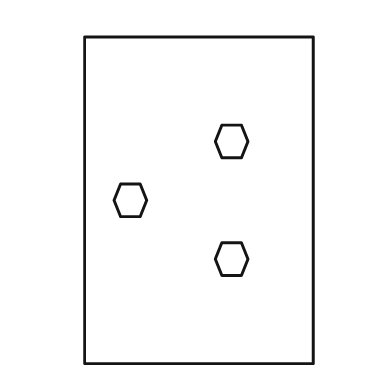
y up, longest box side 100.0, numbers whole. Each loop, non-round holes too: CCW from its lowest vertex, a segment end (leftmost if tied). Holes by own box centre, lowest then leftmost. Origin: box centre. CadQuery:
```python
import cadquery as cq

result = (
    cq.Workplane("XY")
    .moveTo(-35.0, -50.0)
    .lineTo(35.0, -50.0)
    .lineTo(35.0, 50.0)
    .lineTo(-35.0, 50.0)
    .close()
    .moveTo(7.0, -23.0)
    .lineTo(13.0, -23.0)
    .lineTo(15.0, -18.0)
    .lineTo(13.0, -13.0)
    .lineTo(7.0, -13.0)
    .lineTo(5.0, -18.0)
    .close()
    .moveTo(-24.0, -5.0)
    .lineTo(-18.0, -5.0)
    .lineTo(-16.0, 0.0)
    .lineTo(-18.0, 5.0)
    .lineTo(-24.0, 5.0)
    .lineTo(-26.0, 0.0)
    .close()
    .moveTo(7.0, 13.0)
    .lineTo(13.0, 13.0)
    .lineTo(15.0, 18.0)
    .lineTo(13.0, 23.0)
    .lineTo(7.0, 23.0)
    .lineTo(5.0, 18.0)
    .close()
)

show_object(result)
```